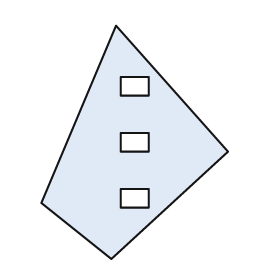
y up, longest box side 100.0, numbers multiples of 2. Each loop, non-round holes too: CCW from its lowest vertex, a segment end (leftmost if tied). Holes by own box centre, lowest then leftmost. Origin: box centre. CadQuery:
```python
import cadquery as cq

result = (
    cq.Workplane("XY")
    .moveTo(-10.0, -50.0)
    .lineTo(40.0, -4.0)
    .lineTo(-8.0, 50.0)
    .lineTo(-40.0, -26.0)
    .close()
    .moveTo(-6.0, -28.0)
    .lineTo(6.0, -28.0)
    .lineTo(6.0, -20.0)
    .lineTo(-6.0, -20.0)
    .close()
    .moveTo(-6.0, -4.0)
    .lineTo(6.0, -4.0)
    .lineTo(6.0, 4.0)
    .lineTo(-6.0, 4.0)
    .close()
    .moveTo(-6.0, 20.0)
    .lineTo(6.0, 20.0)
    .lineTo(6.0, 28.0)
    .lineTo(-6.0, 28.0)
    .close()
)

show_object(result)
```